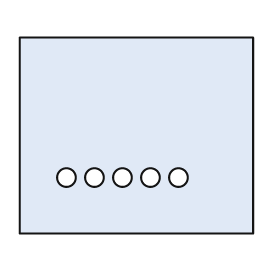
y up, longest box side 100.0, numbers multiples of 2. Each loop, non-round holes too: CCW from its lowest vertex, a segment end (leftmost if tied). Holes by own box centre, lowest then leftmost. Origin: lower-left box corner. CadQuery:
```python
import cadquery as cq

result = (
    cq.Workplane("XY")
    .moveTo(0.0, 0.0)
    .lineTo(100.0, 0.0)
    .lineTo(100.0, 84.0)
    .lineTo(0.0, 84.0)
    .close()
    .moveTo(20.0, 24.0)
    .circle(4.0)
    .moveTo(32.0, 24.0)
    .circle(4.0)
    .moveTo(44.0, 24.0)
    .circle(4.0)
    .moveTo(56.0, 24.0)
    .circle(4.0)
    .moveTo(68.0, 24.0)
    .circle(4.0)
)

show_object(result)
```